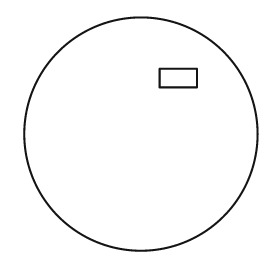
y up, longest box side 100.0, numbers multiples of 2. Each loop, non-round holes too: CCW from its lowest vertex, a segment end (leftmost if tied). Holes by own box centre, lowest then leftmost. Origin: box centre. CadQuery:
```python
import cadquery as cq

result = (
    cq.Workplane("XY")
    .moveTo(0.0, 0.0)
    .circle(50.0)
    .moveTo(8.0, 20.0)
    .lineTo(24.0, 20.0)
    .lineTo(24.0, 28.0)
    .lineTo(8.0, 28.0)
    .close()
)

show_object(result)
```